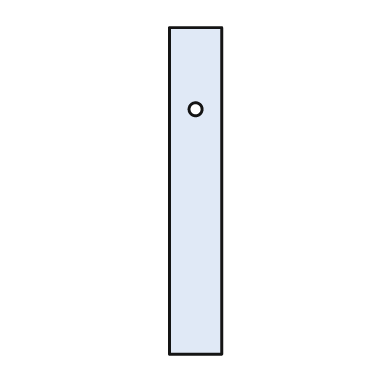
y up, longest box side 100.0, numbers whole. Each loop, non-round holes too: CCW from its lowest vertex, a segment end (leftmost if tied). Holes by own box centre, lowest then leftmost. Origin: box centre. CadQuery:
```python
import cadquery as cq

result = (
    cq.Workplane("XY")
    .moveTo(-8.0, -50.0)
    .lineTo(8.0, -50.0)
    .lineTo(8.0, 50.0)
    .lineTo(-8.0, 50.0)
    .close()
    .moveTo(0.0, 25.0)
    .circle(2.0)
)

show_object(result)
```